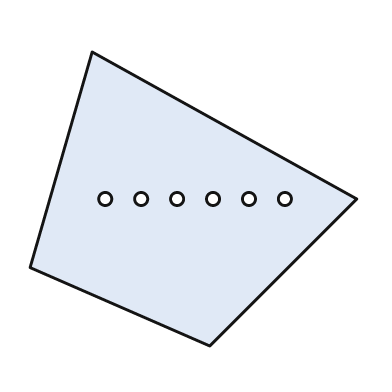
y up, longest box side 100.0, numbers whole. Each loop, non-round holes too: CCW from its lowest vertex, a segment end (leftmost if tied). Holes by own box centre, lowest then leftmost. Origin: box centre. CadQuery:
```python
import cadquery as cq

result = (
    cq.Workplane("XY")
    .moveTo(5.0, -45.0)
    .lineTo(50.0, 0.0)
    .lineTo(-31.0, 45.0)
    .lineTo(-50.0, -21.0)
    .close()
    .moveTo(-27.0, 0.0)
    .circle(2.0)
    .moveTo(-16.0, 0.0)
    .circle(2.0)
    .moveTo(-5.0, 0.0)
    .circle(2.0)
    .moveTo(6.0, 0.0)
    .circle(2.0)
    .moveTo(17.0, 0.0)
    .circle(2.0)
    .moveTo(28.0, 0.0)
    .circle(2.0)
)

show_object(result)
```